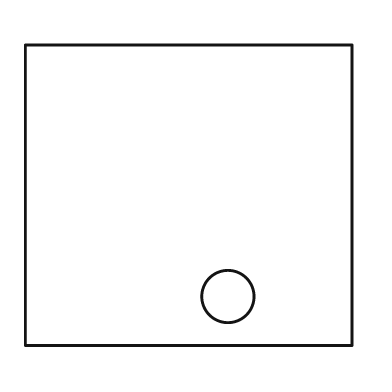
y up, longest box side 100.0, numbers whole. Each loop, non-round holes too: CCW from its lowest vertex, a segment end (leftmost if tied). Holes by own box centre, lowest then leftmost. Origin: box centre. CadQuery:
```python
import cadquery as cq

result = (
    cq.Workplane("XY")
    .moveTo(-50.0, -46.0)
    .lineTo(50.0, -46.0)
    .lineTo(50.0, 46.0)
    .lineTo(-50.0, 46.0)
    .close()
    .moveTo(12.0, -31.0)
    .circle(8.0)
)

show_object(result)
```